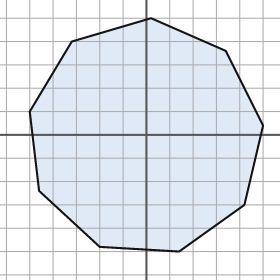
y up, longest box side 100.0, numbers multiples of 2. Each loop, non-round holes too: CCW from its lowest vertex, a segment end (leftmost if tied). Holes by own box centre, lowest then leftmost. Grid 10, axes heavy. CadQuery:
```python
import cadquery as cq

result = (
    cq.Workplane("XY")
    .moveTo(14.0, -50.0)
    .lineTo(42.0, -30.0)
    .lineTo(50.0, 4.0)
    .lineTo(34.0, 36.0)
    .lineTo(2.0, 50.0)
    .lineTo(-32.0, 40.0)
    .lineTo(-50.0, 10.0)
    .lineTo(-46.0, -24.0)
    .lineTo(-20.0, -48.0)
    .close()
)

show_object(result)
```